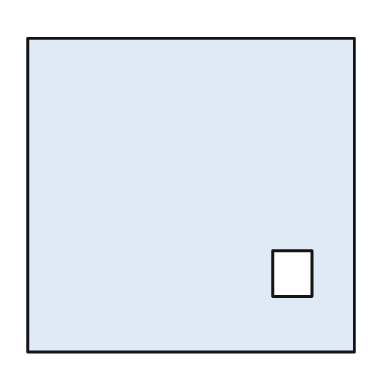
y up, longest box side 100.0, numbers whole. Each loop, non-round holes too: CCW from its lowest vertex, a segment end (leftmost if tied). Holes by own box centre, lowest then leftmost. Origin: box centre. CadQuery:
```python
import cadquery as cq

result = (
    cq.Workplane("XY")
    .moveTo(-50.0, -48.0)
    .lineTo(50.0, -48.0)
    .lineTo(50.0, 48.0)
    .lineTo(-50.0, 48.0)
    .close()
    .moveTo(25.0, -31.0)
    .lineTo(37.0, -31.0)
    .lineTo(37.0, -17.0)
    .lineTo(25.0, -17.0)
    .close()
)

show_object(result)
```